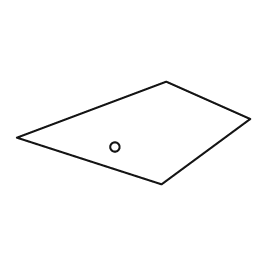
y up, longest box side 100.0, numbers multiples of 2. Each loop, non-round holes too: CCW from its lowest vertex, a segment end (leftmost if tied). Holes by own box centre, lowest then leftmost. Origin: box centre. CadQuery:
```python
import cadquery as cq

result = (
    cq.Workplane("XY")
    .moveTo(12.0, -22.0)
    .lineTo(50.0, 6.0)
    .lineTo(14.0, 22.0)
    .lineTo(-50.0, -2.0)
    .close()
    .moveTo(-8.0, -6.0)
    .circle(2.0)
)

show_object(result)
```